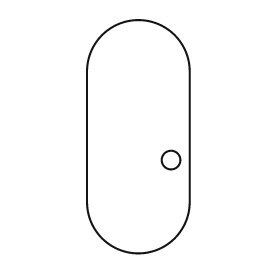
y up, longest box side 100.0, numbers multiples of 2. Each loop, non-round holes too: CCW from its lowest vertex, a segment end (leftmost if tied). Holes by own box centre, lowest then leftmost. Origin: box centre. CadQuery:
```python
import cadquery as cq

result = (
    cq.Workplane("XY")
    .moveTo(-22.0, -28.0)
    .threePointArc((0.0, -50.0), (22.0, -28.0))
    .lineTo(22.0, 28.0)
    .threePointArc((0.0, 50.0), (-22.0, 28.0))
    .close()
    .moveTo(14.0, -10.0)
    .circle(4.0)
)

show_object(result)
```